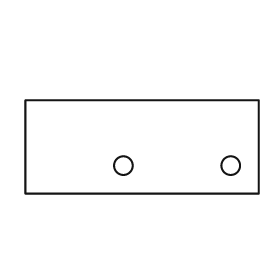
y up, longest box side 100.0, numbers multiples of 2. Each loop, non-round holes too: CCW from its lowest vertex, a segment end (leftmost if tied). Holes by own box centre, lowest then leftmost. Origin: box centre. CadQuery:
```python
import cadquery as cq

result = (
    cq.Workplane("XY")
    .moveTo(-50.0, -20.0)
    .lineTo(50.0, -20.0)
    .lineTo(50.0, 20.0)
    .lineTo(-50.0, 20.0)
    .close()
    .moveTo(-8.0, -8.0)
    .circle(4.0)
    .moveTo(38.0, -8.0)
    .circle(4.0)
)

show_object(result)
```